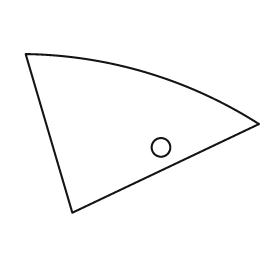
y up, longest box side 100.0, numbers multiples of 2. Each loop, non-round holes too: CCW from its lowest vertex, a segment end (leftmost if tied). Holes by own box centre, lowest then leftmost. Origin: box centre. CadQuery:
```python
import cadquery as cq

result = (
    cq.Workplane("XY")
    .moveTo(-30.0, -34.0)
    .lineTo(50.0, 4.0)
    .threePointArc((2.0, 26.0), (-50.0, 34.0))
    .close()
    .moveTo(8.0, -6.0)
    .circle(4.0)
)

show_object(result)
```